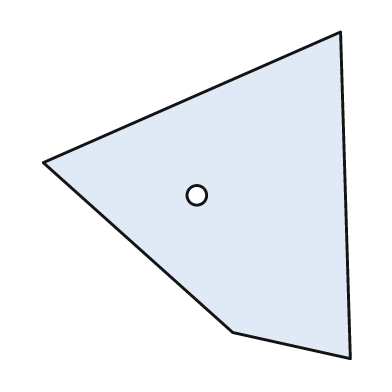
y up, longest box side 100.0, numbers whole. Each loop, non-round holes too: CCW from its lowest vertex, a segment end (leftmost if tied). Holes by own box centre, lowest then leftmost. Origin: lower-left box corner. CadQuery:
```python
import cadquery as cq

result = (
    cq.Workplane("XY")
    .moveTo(94.0, 0.0)
    .lineTo(91.0, 100.0)
    .lineTo(0.0, 60.0)
    .lineTo(58.0, 8.0)
    .close()
    .moveTo(47.0, 50.0)
    .circle(3.0)
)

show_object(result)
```